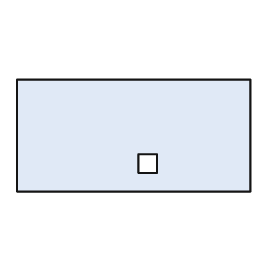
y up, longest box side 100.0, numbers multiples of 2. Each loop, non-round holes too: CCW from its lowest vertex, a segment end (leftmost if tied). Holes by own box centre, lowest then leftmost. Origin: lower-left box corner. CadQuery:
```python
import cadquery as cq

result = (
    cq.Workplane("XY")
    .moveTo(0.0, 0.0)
    .lineTo(100.0, 0.0)
    .lineTo(100.0, 48.0)
    .lineTo(0.0, 48.0)
    .close()
    .moveTo(52.0, 8.0)
    .lineTo(60.0, 8.0)
    .lineTo(60.0, 16.0)
    .lineTo(52.0, 16.0)
    .close()
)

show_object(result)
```